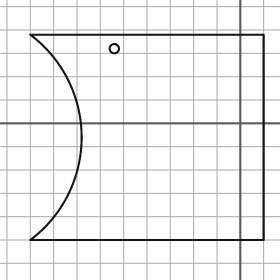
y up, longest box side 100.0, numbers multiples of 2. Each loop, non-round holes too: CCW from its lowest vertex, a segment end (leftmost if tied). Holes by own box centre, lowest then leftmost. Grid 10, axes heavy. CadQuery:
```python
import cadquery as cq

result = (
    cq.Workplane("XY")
    .moveTo(-90.0, -50.0)
    .lineTo(10.0, -50.0)
    .lineTo(10.0, 38.0)
    .lineTo(-90.0, 38.0)
    .threePointArc((-68.0, -6.0), (-90.0, -50.0))
    .close()
    .moveTo(-54.0, 32.0)
    .circle(2.0)
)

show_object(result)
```